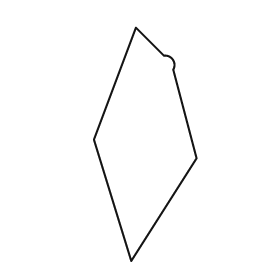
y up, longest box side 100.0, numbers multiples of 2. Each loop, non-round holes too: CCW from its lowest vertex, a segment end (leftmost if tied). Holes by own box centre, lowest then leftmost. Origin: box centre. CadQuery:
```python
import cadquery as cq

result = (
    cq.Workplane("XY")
    .moveTo(-6.0, -50.0)
    .lineTo(22.0, -6.0)
    .lineTo(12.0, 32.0)
    .threePointArc((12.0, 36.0), (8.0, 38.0))
    .lineTo(-4.0, 50.0)
    .lineTo(-22.0, 2.0)
    .close()
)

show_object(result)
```